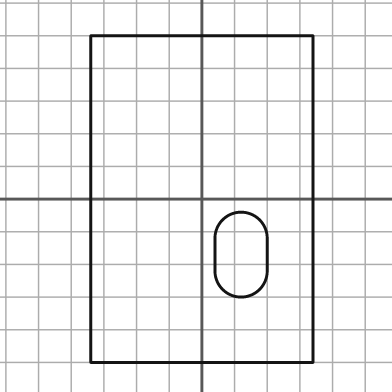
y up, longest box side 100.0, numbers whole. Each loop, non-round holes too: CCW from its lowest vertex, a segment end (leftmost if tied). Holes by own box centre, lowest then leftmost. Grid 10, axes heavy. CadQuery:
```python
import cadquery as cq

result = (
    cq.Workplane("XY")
    .moveTo(-34.0, -50.0)
    .lineTo(34.0, -50.0)
    .lineTo(34.0, 50.0)
    .lineTo(-34.0, 50.0)
    .close()
    .moveTo(4.0, -22.0)
    .threePointArc((12.0, -30.0), (20.0, -22.0))
    .lineTo(20.0, -12.0)
    .threePointArc((12.0, -4.0), (4.0, -12.0))
    .close()
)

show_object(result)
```